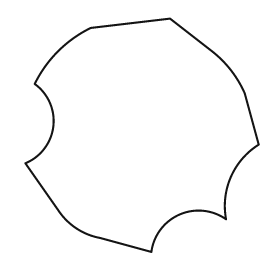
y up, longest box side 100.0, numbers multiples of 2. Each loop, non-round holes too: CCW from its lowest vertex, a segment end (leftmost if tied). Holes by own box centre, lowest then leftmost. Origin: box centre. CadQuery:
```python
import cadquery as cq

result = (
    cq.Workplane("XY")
    .moveTo(4.0, -50.0)
    .threePointArc((16.0, -34.0), (36.0, -36.0))
    .threePointArc((38.0, -18.0), (50.0, -4.0))
    .lineTo(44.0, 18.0)
    .threePointArc((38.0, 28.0), (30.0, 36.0))
    .lineTo(12.0, 50.0)
    .lineTo(-22.0, 46.0)
    .threePointArc((-36.0, 36.0), (-46.0, 22.0))
    .threePointArc((-38.0, 4.0), (-50.0, -12.0))
    .lineTo(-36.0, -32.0)
    .threePointArc((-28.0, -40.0), (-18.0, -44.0))
    .close()
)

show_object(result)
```